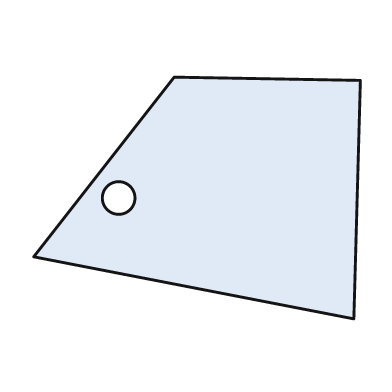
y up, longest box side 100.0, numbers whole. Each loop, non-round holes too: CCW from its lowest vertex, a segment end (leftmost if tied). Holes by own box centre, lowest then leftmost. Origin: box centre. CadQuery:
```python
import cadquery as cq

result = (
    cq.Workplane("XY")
    .moveTo(48.0, -37.0)
    .lineTo(50.0, 36.0)
    .lineTo(-7.0, 37.0)
    .lineTo(-50.0, -18.0)
    .close()
    .moveTo(-24.0, 0.0)
    .circle(5.0)
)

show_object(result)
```